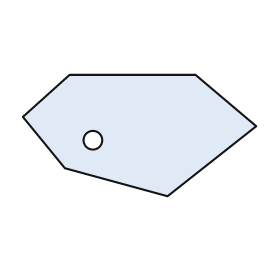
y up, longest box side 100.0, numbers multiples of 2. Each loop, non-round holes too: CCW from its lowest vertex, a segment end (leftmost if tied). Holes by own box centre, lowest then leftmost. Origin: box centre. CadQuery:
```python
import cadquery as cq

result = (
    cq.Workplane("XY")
    .moveTo(12.0, -26.0)
    .lineTo(50.0, 4.0)
    .lineTo(24.0, 26.0)
    .lineTo(-30.0, 26.0)
    .lineTo(-50.0, 8.0)
    .lineTo(-32.0, -14.0)
    .close()
    .moveTo(-20.0, -2.0)
    .circle(4.0)
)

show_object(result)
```